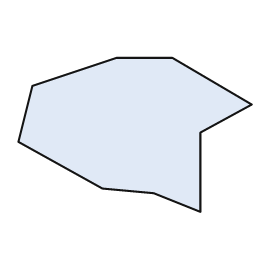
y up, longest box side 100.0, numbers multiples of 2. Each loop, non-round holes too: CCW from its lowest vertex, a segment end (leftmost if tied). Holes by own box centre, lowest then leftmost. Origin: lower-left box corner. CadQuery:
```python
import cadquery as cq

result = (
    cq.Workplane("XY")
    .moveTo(78.0, 0.0)
    .lineTo(78.0, 34.0)
    .lineTo(100.0, 46.0)
    .lineTo(66.0, 66.0)
    .lineTo(42.0, 66.0)
    .lineTo(6.0, 54.0)
    .lineTo(0.0, 30.0)
    .lineTo(36.0, 10.0)
    .lineTo(58.0, 8.0)
    .close()
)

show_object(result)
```